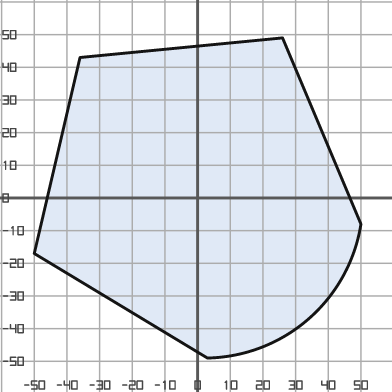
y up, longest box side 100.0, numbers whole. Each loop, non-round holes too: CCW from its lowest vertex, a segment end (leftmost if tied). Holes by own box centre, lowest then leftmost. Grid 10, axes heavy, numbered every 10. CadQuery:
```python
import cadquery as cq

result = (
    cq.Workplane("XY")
    .moveTo(3.0, -49.0)
    .threePointArc((34.0, -37.0), (50.0, -8.0))
    .lineTo(26.0, 49.0)
    .lineTo(-36.0, 43.0)
    .lineTo(-50.0, -17.0)
    .close()
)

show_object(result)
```